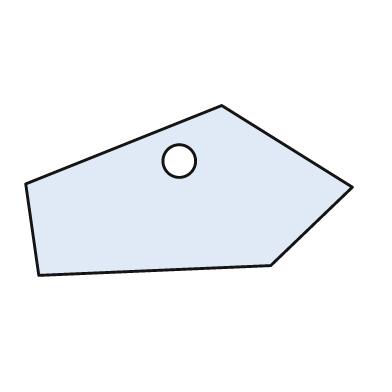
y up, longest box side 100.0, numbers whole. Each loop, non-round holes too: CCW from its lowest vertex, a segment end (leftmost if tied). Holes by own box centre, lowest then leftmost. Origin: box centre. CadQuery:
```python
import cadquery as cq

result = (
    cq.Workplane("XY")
    .moveTo(-46.0, -26.0)
    .lineTo(25.0, -23.0)
    .lineTo(50.0, 1.0)
    .lineTo(10.0, 26.0)
    .lineTo(-50.0, 2.0)
    .close()
    .moveTo(-3.0, 9.0)
    .circle(5.0)
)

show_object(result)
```